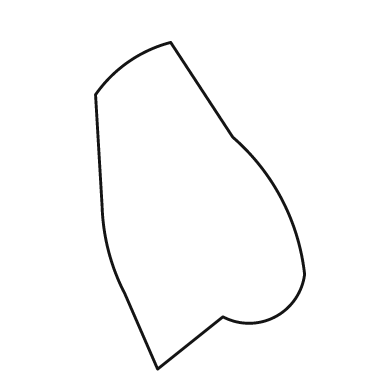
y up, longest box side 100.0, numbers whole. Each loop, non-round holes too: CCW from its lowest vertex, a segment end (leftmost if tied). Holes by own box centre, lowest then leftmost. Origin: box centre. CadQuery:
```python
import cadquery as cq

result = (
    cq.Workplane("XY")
    .moveTo(-13.0, -50.0)
    .lineTo(7.0, -34.0)
    .threePointArc((23.0, -34.0), (32.0, -21.0))
    .threePointArc((25.0, 2.0), (10.0, 21.0))
    .lineTo(-9.0, 50.0)
    .threePointArc((-22.0, 44.0), (-32.0, 34.0))
    .lineTo(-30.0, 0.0)
    .threePointArc((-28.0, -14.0), (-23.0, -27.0))
    .close()
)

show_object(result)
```